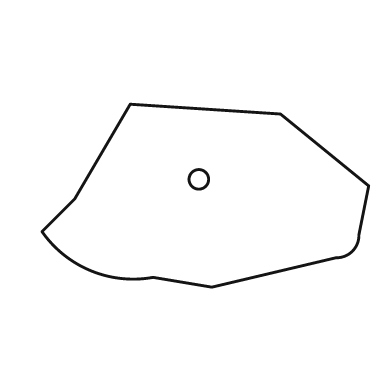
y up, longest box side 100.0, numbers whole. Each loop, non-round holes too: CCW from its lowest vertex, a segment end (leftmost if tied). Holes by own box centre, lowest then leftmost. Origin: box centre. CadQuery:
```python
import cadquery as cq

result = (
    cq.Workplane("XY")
    .moveTo(2.0, -28.0)
    .lineTo(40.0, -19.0)
    .threePointArc((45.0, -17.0), (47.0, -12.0))
    .lineTo(50.0, 3.0)
    .lineTo(23.0, 25.0)
    .lineTo(-23.0, 28.0)
    .lineTo(-40.0, -1.0)
    .lineTo(-50.0, -11.0)
    .threePointArc((-35.0, -23.0), (-16.0, -25.0))
    .close()
    .moveTo(-2.0, 5.0)
    .circle(3.0)
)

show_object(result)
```